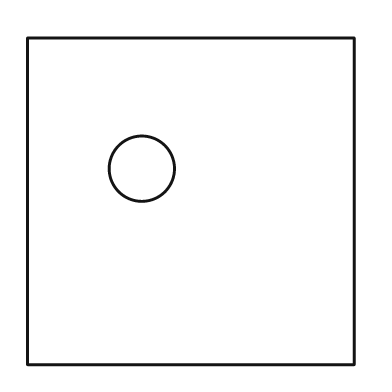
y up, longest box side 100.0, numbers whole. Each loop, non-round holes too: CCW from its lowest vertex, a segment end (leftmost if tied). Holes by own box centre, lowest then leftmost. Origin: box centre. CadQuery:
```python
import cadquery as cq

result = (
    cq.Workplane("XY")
    .moveTo(-50.0, -50.0)
    .lineTo(50.0, -50.0)
    .lineTo(50.0, 50.0)
    .lineTo(-50.0, 50.0)
    .close()
    .moveTo(-15.0, 10.0)
    .circle(10.0)
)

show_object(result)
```